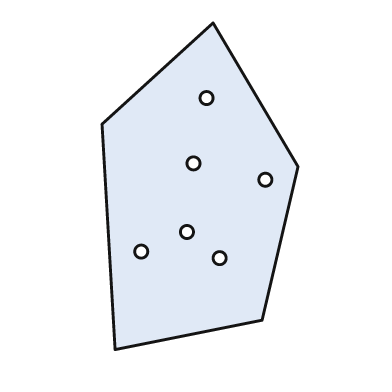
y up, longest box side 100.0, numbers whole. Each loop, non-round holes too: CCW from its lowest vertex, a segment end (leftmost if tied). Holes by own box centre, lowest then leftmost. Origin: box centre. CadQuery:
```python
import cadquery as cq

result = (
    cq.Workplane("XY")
    .moveTo(-26.0, -50.0)
    .lineTo(19.0, -41.0)
    .lineTo(30.0, 6.0)
    .lineTo(4.0, 50.0)
    .lineTo(-30.0, 19.0)
    .close()
    .moveTo(6.0, -22.0)
    .circle(2.0)
    .moveTo(-18.0, -20.0)
    .circle(2.0)
    .moveTo(-4.0, -14.0)
    .circle(2.0)
    .moveTo(20.0, 2.0)
    .circle(2.0)
    .moveTo(-2.0, 7.0)
    .circle(2.0)
    .moveTo(2.0, 27.0)
    .circle(2.0)
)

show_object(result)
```